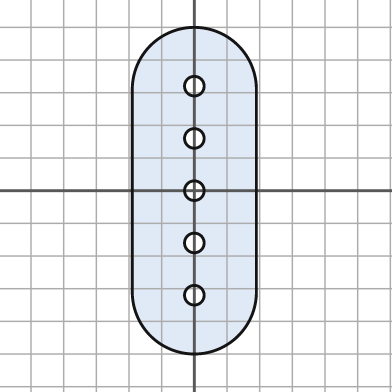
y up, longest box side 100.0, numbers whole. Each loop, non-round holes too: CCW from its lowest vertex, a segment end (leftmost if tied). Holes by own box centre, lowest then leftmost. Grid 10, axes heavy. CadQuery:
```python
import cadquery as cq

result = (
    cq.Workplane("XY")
    .moveTo(-19.0, -31.0)
    .threePointArc((0.0, -50.0), (19.0, -31.0))
    .lineTo(19.0, 31.0)
    .threePointArc((0.0, 50.0), (-19.0, 31.0))
    .close()
    .moveTo(0.0, -32.0)
    .circle(3.0)
    .moveTo(0.0, -16.0)
    .circle(3.0)
    .moveTo(0.0, 0.0)
    .circle(3.0)
    .moveTo(0.0, 16.0)
    .circle(3.0)
    .moveTo(0.0, 32.0)
    .circle(3.0)
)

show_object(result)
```